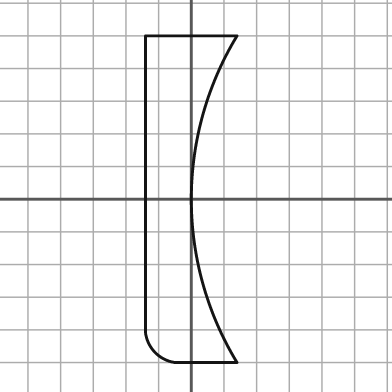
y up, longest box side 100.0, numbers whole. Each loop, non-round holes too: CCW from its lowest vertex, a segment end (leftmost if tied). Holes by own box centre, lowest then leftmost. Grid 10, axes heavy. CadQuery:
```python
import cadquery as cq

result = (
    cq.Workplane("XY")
    .moveTo(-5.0, -50.0)
    .lineTo(14.0, -50.0)
    .threePointArc((0.0, 0.0), (14.0, 50.0))
    .lineTo(-14.0, 50.0)
    .lineTo(-14.0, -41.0)
    .threePointArc((-11.0, -47.0), (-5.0, -50.0))
    .close()
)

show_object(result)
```